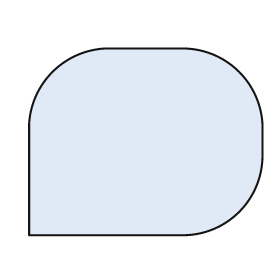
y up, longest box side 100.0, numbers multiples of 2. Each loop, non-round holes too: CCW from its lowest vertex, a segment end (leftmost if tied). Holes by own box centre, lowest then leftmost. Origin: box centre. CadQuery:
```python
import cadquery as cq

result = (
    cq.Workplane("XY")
    .moveTo(-50.0, -40.0)
    .lineTo(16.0, -40.0)
    .threePointArc((40.0, -30.0), (50.0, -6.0))
    .lineTo(50.0, 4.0)
    .threePointArc((40.0, 30.0), (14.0, 40.0))
    .lineTo(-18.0, 40.0)
    .threePointArc((-40.0, 30.0), (-50.0, 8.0))
    .close()
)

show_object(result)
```